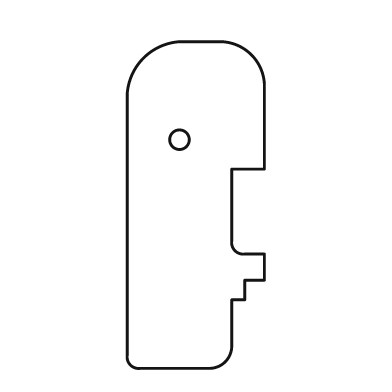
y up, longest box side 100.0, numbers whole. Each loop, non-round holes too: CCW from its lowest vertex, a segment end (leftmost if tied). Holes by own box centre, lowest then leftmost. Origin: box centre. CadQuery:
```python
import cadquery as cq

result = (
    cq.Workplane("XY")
    .moveTo(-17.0, -50.0)
    .lineTo(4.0, -50.0)
    .threePointArc((9.0, -48.0), (11.0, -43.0))
    .lineTo(11.0, -29.0)
    .lineTo(15.0, -29.0)
    .lineTo(15.0, -23.0)
    .lineTo(21.0, -23.0)
    .lineTo(21.0, -15.0)
    .lineTo(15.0, -15.0)
    .threePointArc((12.0, -14.0), (11.0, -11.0))
    .lineTo(11.0, 11.0)
    .lineTo(21.0, 11.0)
    .lineTo(21.0, 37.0)
    .threePointArc((17.0, 46.0), (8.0, 50.0))
    .lineTo(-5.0, 50.0)
    .threePointArc((-16.0, 45.0), (-21.0, 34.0))
    .lineTo(-21.0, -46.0)
    .threePointArc((-20.0, -49.0), (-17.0, -50.0))
    .close()
    .moveTo(-5.0, 20.0)
    .circle(3.0)
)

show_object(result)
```